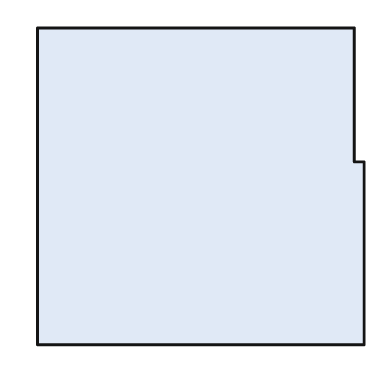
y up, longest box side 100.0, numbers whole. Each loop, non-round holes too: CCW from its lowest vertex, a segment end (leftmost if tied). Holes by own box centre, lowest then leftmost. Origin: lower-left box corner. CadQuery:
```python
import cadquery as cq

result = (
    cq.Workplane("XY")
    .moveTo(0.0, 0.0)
    .lineTo(100.0, 0.0)
    .lineTo(100.0, 56.0)
    .lineTo(97.0, 56.0)
    .lineTo(97.0, 97.0)
    .lineTo(0.0, 97.0)
    .close()
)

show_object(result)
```